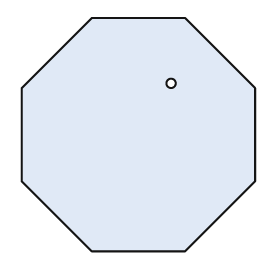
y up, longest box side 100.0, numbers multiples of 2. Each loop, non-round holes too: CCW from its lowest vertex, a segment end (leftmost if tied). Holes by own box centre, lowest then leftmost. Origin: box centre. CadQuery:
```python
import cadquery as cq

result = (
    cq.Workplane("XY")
    .moveTo(-20.0, -50.0)
    .lineTo(20.0, -50.0)
    .lineTo(50.0, -20.0)
    .lineTo(50.0, 20.0)
    .lineTo(20.0, 50.0)
    .lineTo(-20.0, 50.0)
    .lineTo(-50.0, 20.0)
    .lineTo(-50.0, -20.0)
    .close()
    .moveTo(14.0, 22.0)
    .circle(2.0)
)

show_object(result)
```